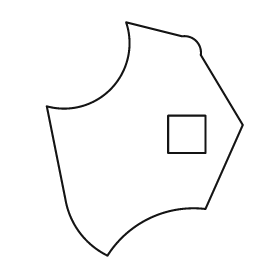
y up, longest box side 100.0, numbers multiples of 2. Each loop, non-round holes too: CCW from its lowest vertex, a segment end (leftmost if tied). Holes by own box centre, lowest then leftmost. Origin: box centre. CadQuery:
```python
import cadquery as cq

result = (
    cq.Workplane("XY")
    .moveTo(-16.0, -50.0)
    .threePointArc((2.0, -34.0), (26.0, -30.0))
    .lineTo(42.0, 6.0)
    .lineTo(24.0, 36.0)
    .threePointArc((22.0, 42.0), (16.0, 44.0))
    .lineTo(-8.0, 50.0)
    .threePointArc((-14.0, 22.0), (-42.0, 14.0))
    .lineTo(-34.0, -26.0)
    .threePointArc((-28.0, -40.0), (-16.0, -50.0))
    .close()
    .moveTo(10.0, -6.0)
    .lineTo(26.0, -6.0)
    .lineTo(26.0, 10.0)
    .lineTo(10.0, 10.0)
    .close()
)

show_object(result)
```